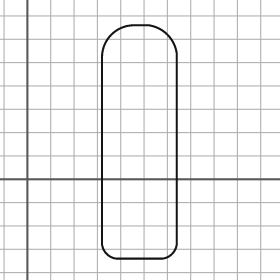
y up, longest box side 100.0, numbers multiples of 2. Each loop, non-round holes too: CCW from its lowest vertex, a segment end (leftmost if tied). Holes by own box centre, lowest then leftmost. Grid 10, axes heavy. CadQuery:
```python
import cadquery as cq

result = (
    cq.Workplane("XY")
    .moveTo(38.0, -34.0)
    .lineTo(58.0, -34.0)
    .threePointArc((62.0, -32.0), (64.0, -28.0))
    .lineTo(64.0, 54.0)
    .threePointArc((60.0, 62.0), (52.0, 66.0))
    .lineTo(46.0, 66.0)
    .threePointArc((36.0, 62.0), (32.0, 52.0))
    .lineTo(32.0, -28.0)
    .threePointArc((34.0, -32.0), (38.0, -34.0))
    .close()
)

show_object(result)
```